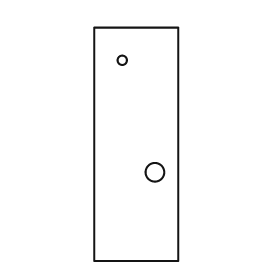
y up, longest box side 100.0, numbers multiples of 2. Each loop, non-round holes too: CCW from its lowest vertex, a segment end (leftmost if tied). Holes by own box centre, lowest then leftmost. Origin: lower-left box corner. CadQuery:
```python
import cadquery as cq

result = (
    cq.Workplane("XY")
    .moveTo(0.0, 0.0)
    .lineTo(36.0, 0.0)
    .lineTo(36.0, 100.0)
    .lineTo(0.0, 100.0)
    .close()
    .moveTo(26.0, 38.0)
    .circle(4.0)
    .moveTo(12.0, 86.0)
    .circle(2.0)
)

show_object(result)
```